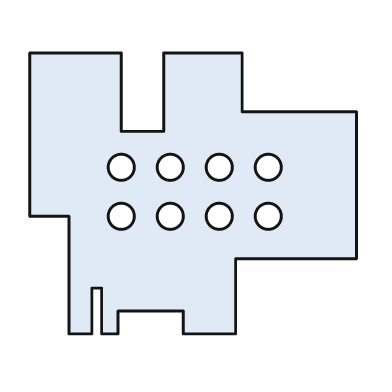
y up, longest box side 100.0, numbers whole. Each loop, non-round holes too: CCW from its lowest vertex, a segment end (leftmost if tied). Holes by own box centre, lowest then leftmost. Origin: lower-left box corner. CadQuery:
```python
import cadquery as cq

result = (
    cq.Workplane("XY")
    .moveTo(12.0, 0.0)
    .lineTo(19.0, 0.0)
    .lineTo(19.0, 14.0)
    .lineTo(22.0, 14.0)
    .lineTo(22.0, 0.0)
    .lineTo(27.0, 0.0)
    .lineTo(27.0, 7.0)
    .lineTo(47.0, 7.0)
    .lineTo(47.0, 0.0)
    .lineTo(63.0, 0.0)
    .lineTo(63.0, 23.0)
    .lineTo(100.0, 23.0)
    .lineTo(100.0, 68.0)
    .lineTo(65.0, 68.0)
    .lineTo(65.0, 86.0)
    .lineTo(41.0, 86.0)
    .lineTo(41.0, 62.0)
    .lineTo(28.0, 62.0)
    .lineTo(28.0, 86.0)
    .lineTo(0.0, 86.0)
    .lineTo(0.0, 36.0)
    .lineTo(12.0, 36.0)
    .close()
    .moveTo(28.0, 36.0)
    .circle(4.0)
    .moveTo(43.0, 36.0)
    .circle(4.0)
    .moveTo(58.0, 36.0)
    .circle(4.0)
    .moveTo(73.0, 36.0)
    .circle(4.0)
    .moveTo(28.0, 51.0)
    .circle(4.0)
    .moveTo(43.0, 51.0)
    .circle(4.0)
    .moveTo(58.0, 51.0)
    .circle(4.0)
    .moveTo(73.0, 51.0)
    .circle(4.0)
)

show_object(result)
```